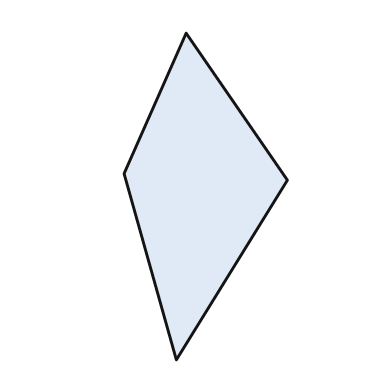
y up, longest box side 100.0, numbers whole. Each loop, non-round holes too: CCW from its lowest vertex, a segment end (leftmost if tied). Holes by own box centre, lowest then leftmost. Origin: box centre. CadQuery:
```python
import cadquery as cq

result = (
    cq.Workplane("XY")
    .moveTo(-9.0, -50.0)
    .lineTo(25.0, 5.0)
    .lineTo(-6.0, 50.0)
    .lineTo(-25.0, 7.0)
    .close()
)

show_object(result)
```